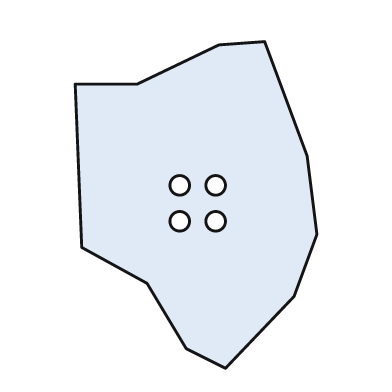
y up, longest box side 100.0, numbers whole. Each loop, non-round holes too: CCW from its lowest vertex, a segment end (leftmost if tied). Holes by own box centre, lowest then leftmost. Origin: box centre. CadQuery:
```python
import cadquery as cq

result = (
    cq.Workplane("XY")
    .moveTo(9.0, -50.0)
    .lineTo(30.0, -28.0)
    .lineTo(37.0, -9.0)
    .lineTo(34.0, 15.0)
    .lineTo(21.0, 50.0)
    .lineTo(7.0, 49.0)
    .lineTo(-18.0, 37.0)
    .lineTo(-37.0, 37.0)
    .lineTo(-35.0, -13.0)
    .lineTo(-15.0, -24.0)
    .lineTo(-3.0, -44.0)
    .close()
    .moveTo(-5.0, -5.0)
    .circle(3.0)
    .moveTo(6.0, -5.0)
    .circle(3.0)
    .moveTo(-5.0, 6.0)
    .circle(3.0)
    .moveTo(6.0, 6.0)
    .circle(3.0)
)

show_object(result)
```